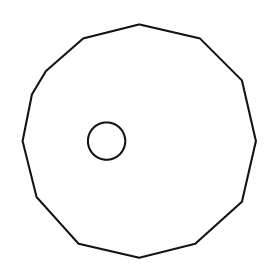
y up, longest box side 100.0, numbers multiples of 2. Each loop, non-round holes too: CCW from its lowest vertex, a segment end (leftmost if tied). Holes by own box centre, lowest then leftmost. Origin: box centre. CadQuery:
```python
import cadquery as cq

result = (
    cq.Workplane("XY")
    .moveTo(0.0, -50.0)
    .lineTo(24.0, -44.0)
    .lineTo(44.0, -26.0)
    .lineTo(50.0, 0.0)
    .lineTo(44.0, 26.0)
    .lineTo(26.0, 44.0)
    .lineTo(0.0, 50.0)
    .lineTo(-24.0, 44.0)
    .lineTo(-40.0, 30.0)
    .lineTo(-46.0, 20.0)
    .lineTo(-50.0, 0.0)
    .lineTo(-44.0, -24.0)
    .lineTo(-26.0, -44.0)
    .close()
    .moveTo(-14.0, 0.0)
    .circle(8.0)
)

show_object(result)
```